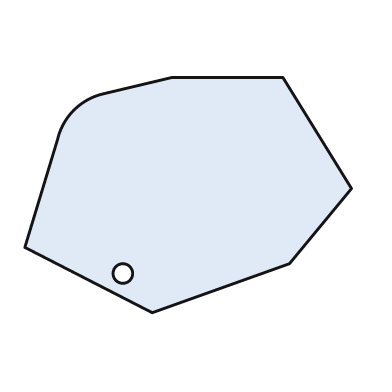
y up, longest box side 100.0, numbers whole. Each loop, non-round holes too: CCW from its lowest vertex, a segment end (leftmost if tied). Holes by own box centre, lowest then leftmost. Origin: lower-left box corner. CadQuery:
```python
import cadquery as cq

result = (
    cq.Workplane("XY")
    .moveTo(39.0, 0.0)
    .lineTo(81.0, 15.0)
    .lineTo(100.0, 38.0)
    .lineTo(79.0, 72.0)
    .lineTo(45.0, 72.0)
    .lineTo(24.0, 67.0)
    .threePointArc((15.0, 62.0), (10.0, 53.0))
    .lineTo(0.0, 20.0)
    .close()
    .moveTo(30.0, 12.0)
    .circle(3.0)
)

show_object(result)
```